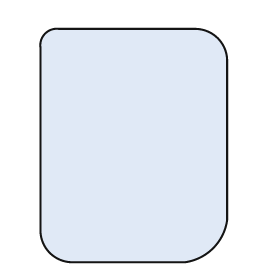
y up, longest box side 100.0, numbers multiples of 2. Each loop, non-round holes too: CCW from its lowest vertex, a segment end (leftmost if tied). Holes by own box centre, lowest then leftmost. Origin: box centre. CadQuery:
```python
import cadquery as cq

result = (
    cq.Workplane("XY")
    .moveTo(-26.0, -50.0)
    .lineTo(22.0, -50.0)
    .threePointArc((34.0, -44.0), (40.0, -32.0))
    .lineTo(40.0, 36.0)
    .threePointArc((36.0, 46.0), (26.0, 50.0))
    .lineTo(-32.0, 50.0)
    .threePointArc((-38.0, 48.0), (-40.0, 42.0))
    .lineTo(-40.0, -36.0)
    .threePointArc((-36.0, -46.0), (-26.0, -50.0))
    .close()
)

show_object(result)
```